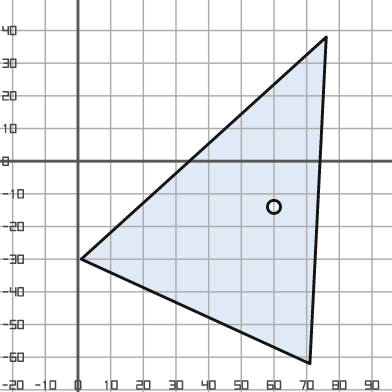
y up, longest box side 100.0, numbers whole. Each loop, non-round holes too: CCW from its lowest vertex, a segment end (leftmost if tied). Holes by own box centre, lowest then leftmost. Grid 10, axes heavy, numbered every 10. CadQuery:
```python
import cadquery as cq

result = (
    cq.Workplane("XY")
    .moveTo(71.0, -62.0)
    .lineTo(76.0, 38.0)
    .lineTo(1.0, -30.0)
    .close()
    .moveTo(60.0, -14.0)
    .circle(2.0)
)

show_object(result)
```